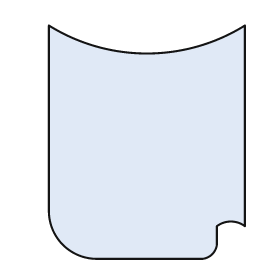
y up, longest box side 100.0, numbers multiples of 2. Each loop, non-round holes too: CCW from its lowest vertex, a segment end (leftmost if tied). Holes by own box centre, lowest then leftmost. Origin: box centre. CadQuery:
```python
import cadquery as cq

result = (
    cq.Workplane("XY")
    .moveTo(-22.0, -50.0)
    .lineTo(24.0, -50.0)
    .threePointArc((28.0, -48.0), (30.0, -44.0))
    .lineTo(30.0, -36.0)
    .threePointArc((36.0, -34.0), (42.0, -36.0))
    .lineTo(42.0, 50.0)
    .threePointArc((0.0, 38.0), (-42.0, 50.0))
    .lineTo(-42.0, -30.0)
    .threePointArc((-36.0, -44.0), (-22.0, -50.0))
    .close()
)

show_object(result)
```